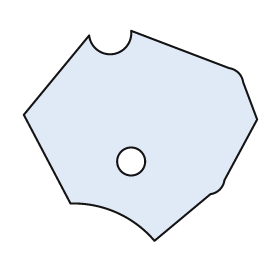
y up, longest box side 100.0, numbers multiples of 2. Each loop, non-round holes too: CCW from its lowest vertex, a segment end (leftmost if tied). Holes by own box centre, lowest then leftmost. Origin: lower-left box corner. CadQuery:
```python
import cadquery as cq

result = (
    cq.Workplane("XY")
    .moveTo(56.0, 0.0)
    .lineTo(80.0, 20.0)
    .threePointArc((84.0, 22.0), (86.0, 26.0))
    .lineTo(100.0, 52.0)
    .lineTo(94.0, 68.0)
    .threePointArc((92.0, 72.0), (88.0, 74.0))
    .lineTo(46.0, 90.0)
    .threePointArc((38.0, 80.0), (28.0, 88.0))
    .lineTo(0.0, 54.0)
    .lineTo(20.0, 16.0)
    .threePointArc((40.0, 12.0), (56.0, 0.0))
    .close()
    .moveTo(46.0, 34.0)
    .circle(6.0)
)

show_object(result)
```